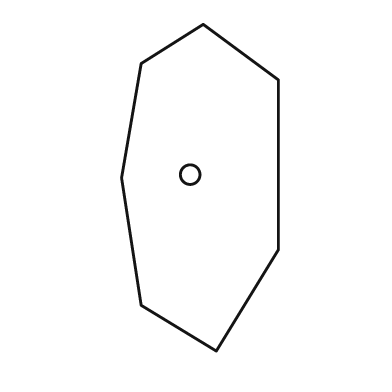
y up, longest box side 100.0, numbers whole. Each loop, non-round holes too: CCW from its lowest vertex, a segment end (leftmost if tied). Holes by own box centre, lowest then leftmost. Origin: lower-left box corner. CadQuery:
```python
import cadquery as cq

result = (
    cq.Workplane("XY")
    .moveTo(29.0, 0.0)
    .lineTo(48.0, 31.0)
    .lineTo(48.0, 83.0)
    .lineTo(25.0, 100.0)
    .lineTo(6.0, 88.0)
    .lineTo(0.0, 53.0)
    .lineTo(6.0, 14.0)
    .close()
    .moveTo(21.0, 54.0)
    .circle(3.0)
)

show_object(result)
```